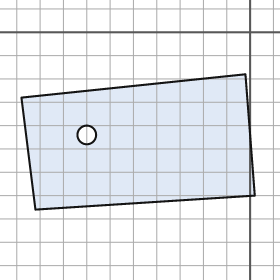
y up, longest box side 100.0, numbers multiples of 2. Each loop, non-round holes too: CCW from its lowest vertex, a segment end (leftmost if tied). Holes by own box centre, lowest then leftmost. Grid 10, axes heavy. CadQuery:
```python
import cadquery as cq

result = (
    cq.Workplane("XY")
    .moveTo(-92.0, -76.0)
    .lineTo(2.0, -70.0)
    .lineTo(-2.0, -18.0)
    .lineTo(-98.0, -28.0)
    .close()
    .moveTo(-70.0, -44.0)
    .circle(4.0)
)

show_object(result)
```